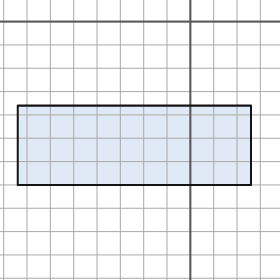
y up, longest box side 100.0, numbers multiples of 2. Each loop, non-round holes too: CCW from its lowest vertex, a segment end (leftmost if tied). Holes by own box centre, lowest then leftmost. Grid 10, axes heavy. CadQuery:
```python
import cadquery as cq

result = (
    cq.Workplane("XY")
    .moveTo(-74.0, -70.0)
    .lineTo(26.0, -70.0)
    .lineTo(26.0, -36.0)
    .lineTo(-74.0, -36.0)
    .close()
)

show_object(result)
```